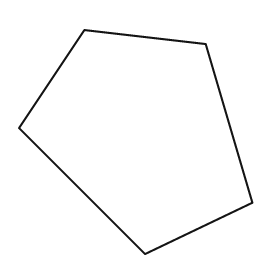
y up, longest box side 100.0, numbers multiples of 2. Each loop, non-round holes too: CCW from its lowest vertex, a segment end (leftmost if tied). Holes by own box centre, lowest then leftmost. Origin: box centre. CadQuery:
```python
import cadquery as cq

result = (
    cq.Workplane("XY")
    .moveTo(4.0, -48.0)
    .lineTo(50.0, -26.0)
    .lineTo(30.0, 42.0)
    .lineTo(-22.0, 48.0)
    .lineTo(-50.0, 6.0)
    .close()
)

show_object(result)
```